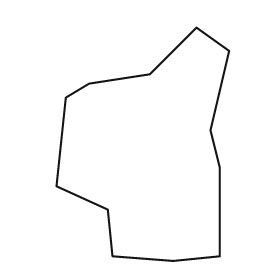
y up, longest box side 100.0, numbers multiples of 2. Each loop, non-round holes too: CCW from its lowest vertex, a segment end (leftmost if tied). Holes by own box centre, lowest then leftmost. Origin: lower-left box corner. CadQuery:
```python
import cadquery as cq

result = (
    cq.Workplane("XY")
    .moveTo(50.0, 0.0)
    .lineTo(70.0, 2.0)
    .lineTo(70.0, 40.0)
    .lineTo(66.0, 56.0)
    .lineTo(74.0, 90.0)
    .lineTo(60.0, 100.0)
    .lineTo(40.0, 80.0)
    .lineTo(14.0, 76.0)
    .lineTo(4.0, 70.0)
    .lineTo(0.0, 32.0)
    .lineTo(22.0, 22.0)
    .lineTo(24.0, 2.0)
    .close()
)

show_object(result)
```